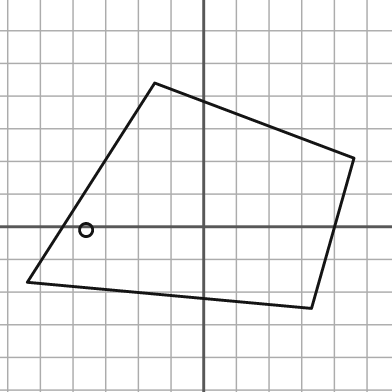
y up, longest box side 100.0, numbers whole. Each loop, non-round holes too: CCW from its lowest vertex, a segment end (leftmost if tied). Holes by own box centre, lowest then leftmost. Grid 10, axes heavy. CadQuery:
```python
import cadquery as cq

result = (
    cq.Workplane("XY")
    .moveTo(33.0, -25.0)
    .lineTo(46.0, 21.0)
    .lineTo(-15.0, 44.0)
    .lineTo(-54.0, -17.0)
    .close()
    .moveTo(-36.0, -1.0)
    .circle(2.0)
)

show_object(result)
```